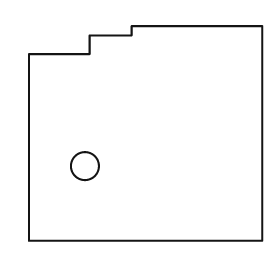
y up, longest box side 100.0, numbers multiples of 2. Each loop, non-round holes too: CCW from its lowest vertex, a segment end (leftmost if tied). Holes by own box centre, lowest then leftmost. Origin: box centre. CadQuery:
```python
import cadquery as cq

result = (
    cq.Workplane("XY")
    .moveTo(-50.0, -46.0)
    .lineTo(50.0, -46.0)
    .lineTo(50.0, 46.0)
    .lineTo(-6.0, 46.0)
    .lineTo(-6.0, 42.0)
    .lineTo(-24.0, 42.0)
    .lineTo(-24.0, 34.0)
    .lineTo(-50.0, 34.0)
    .close()
    .moveTo(-26.0, -14.0)
    .circle(6.0)
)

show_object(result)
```